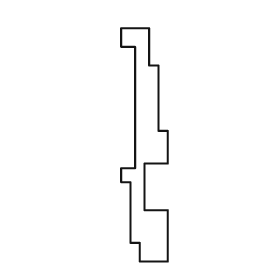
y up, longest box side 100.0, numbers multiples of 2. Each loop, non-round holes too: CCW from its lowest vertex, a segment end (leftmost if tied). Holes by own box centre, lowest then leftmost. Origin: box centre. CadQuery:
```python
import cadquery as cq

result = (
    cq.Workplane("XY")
    .moveTo(-2.0, -50.0)
    .lineTo(10.0, -50.0)
    .lineTo(10.0, -28.0)
    .lineTo(0.0, -28.0)
    .lineTo(0.0, -8.0)
    .lineTo(10.0, -8.0)
    .lineTo(10.0, 6.0)
    .lineTo(6.0, 6.0)
    .lineTo(6.0, 34.0)
    .lineTo(2.0, 34.0)
    .lineTo(2.0, 50.0)
    .lineTo(-10.0, 50.0)
    .lineTo(-10.0, 42.0)
    .lineTo(-4.0, 42.0)
    .lineTo(-4.0, -10.0)
    .lineTo(-10.0, -10.0)
    .lineTo(-10.0, -16.0)
    .lineTo(-6.0, -16.0)
    .lineTo(-6.0, -42.0)
    .lineTo(-2.0, -42.0)
    .close()
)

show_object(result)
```